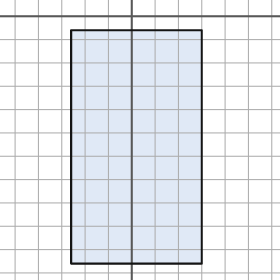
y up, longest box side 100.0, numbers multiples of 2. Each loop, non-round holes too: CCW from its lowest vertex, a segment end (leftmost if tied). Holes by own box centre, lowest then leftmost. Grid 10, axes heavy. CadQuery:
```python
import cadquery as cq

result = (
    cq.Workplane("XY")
    .moveTo(-26.0, -106.0)
    .lineTo(30.0, -106.0)
    .lineTo(30.0, -6.0)
    .lineTo(-26.0, -6.0)
    .close()
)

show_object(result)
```